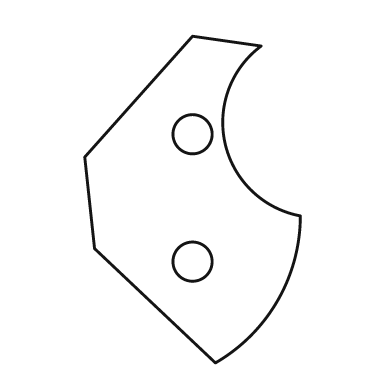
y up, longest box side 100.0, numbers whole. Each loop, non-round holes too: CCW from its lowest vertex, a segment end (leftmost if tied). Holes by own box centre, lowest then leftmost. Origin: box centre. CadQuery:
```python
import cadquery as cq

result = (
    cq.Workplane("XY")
    .moveTo(7.0, -50.0)
    .threePointArc((26.0, -31.0), (33.0, -5.0))
    .threePointArc((10.0, 17.0), (21.0, 47.0))
    .lineTo(0.0, 50.0)
    .lineTo(-33.0, 13.0)
    .lineTo(-30.0, -15.0)
    .close()
    .moveTo(0.0, -19.0)
    .circle(6.0)
    .moveTo(0.0, 20.0)
    .circle(6.0)
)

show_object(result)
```